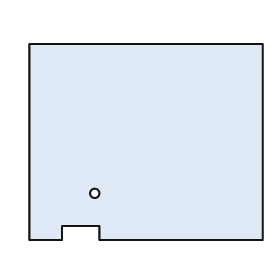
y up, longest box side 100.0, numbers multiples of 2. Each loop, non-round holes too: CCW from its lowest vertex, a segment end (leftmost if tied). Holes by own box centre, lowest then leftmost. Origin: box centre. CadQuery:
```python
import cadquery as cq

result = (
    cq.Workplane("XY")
    .moveTo(-50.0, -42.0)
    .lineTo(-36.0, -42.0)
    .lineTo(-36.0, -36.0)
    .lineTo(-20.0, -36.0)
    .lineTo(-20.0, -42.0)
    .lineTo(50.0, -42.0)
    .lineTo(50.0, 42.0)
    .lineTo(-50.0, 42.0)
    .close()
    .moveTo(-22.0, -22.0)
    .circle(2.0)
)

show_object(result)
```